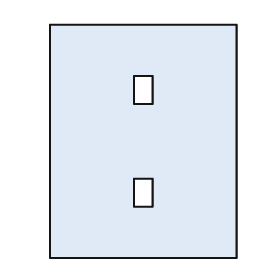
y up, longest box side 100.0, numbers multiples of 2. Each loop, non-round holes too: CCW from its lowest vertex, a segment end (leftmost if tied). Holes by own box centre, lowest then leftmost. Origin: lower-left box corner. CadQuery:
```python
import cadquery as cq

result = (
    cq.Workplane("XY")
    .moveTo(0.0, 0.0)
    .lineTo(80.0, 0.0)
    .lineTo(80.0, 100.0)
    .lineTo(0.0, 100.0)
    .close()
    .moveTo(36.0, 22.0)
    .lineTo(44.0, 22.0)
    .lineTo(44.0, 34.0)
    .lineTo(36.0, 34.0)
    .close()
    .moveTo(36.0, 66.0)
    .lineTo(44.0, 66.0)
    .lineTo(44.0, 78.0)
    .lineTo(36.0, 78.0)
    .close()
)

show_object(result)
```